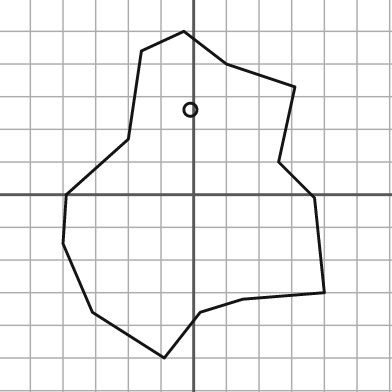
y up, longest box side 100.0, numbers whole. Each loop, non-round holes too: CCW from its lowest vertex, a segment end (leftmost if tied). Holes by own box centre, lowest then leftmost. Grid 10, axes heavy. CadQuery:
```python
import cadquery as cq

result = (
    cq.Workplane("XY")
    .moveTo(-9.0, -50.0)
    .lineTo(2.0, -36.0)
    .lineTo(15.0, -32.0)
    .lineTo(40.0, -30.0)
    .lineTo(37.0, -1.0)
    .lineTo(26.0, 10.0)
    .lineTo(31.0, 33.0)
    .lineTo(10.0, 40.0)
    .lineTo(-3.0, 50.0)
    .lineTo(-16.0, 44.0)
    .lineTo(-20.0, 17.0)
    .lineTo(-39.0, 0.0)
    .lineTo(-40.0, -15.0)
    .lineTo(-31.0, -36.0)
    .close()
    .moveTo(-1.0, 26.0)
    .circle(2.0)
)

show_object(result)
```